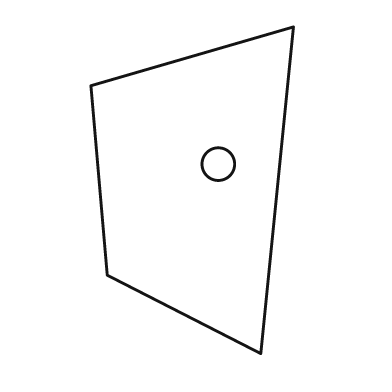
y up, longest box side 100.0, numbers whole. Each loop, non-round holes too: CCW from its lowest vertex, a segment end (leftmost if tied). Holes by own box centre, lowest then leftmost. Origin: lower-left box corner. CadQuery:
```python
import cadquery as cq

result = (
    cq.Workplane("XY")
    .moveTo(52.0, 0.0)
    .lineTo(62.0, 100.0)
    .lineTo(0.0, 82.0)
    .lineTo(5.0, 24.0)
    .close()
    .moveTo(39.0, 58.0)
    .circle(5.0)
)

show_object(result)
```